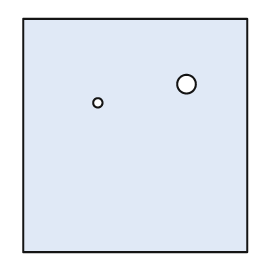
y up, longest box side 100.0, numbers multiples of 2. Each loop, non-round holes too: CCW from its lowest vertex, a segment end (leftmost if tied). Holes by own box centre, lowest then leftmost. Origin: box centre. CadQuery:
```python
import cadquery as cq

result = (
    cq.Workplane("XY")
    .moveTo(-48.0, -50.0)
    .lineTo(48.0, -50.0)
    .lineTo(48.0, 50.0)
    .lineTo(-48.0, 50.0)
    .close()
    .moveTo(-16.0, 14.0)
    .circle(2.0)
    .moveTo(22.0, 22.0)
    .circle(4.0)
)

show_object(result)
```